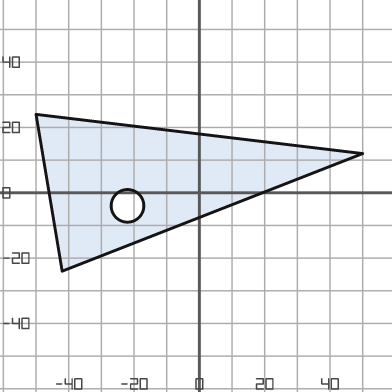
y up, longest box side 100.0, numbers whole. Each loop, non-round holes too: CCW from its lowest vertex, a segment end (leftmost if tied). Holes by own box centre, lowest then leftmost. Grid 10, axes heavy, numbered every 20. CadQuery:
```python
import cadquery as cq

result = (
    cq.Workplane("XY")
    .moveTo(-42.0, -24.0)
    .lineTo(50.0, 12.0)
    .lineTo(-50.0, 24.0)
    .close()
    .moveTo(-22.0, -4.0)
    .circle(5.0)
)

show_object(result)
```